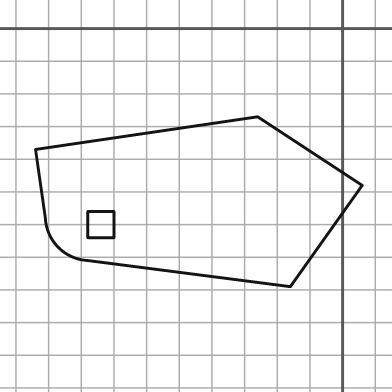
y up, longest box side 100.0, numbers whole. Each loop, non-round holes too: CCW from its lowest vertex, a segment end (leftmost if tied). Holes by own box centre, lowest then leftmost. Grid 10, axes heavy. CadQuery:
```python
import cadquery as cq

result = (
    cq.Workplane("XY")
    .moveTo(-16.0, -79.0)
    .lineTo(6.0, -48.0)
    .lineTo(-26.0, -27.0)
    .lineTo(-94.0, -37.0)
    .lineTo(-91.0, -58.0)
    .threePointArc((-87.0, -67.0), (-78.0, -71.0))
    .close()
    .moveTo(-78.0, -64.0)
    .lineTo(-70.0, -64.0)
    .lineTo(-70.0, -56.0)
    .lineTo(-78.0, -56.0)
    .close()
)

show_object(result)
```